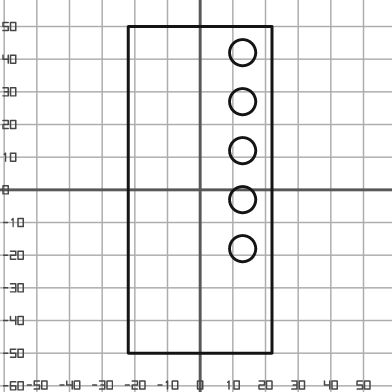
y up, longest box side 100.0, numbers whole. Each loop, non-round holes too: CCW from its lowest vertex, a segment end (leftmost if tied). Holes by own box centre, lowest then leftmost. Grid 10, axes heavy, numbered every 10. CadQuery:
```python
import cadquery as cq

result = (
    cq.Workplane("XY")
    .moveTo(-22.0, -50.0)
    .lineTo(22.0, -50.0)
    .lineTo(22.0, 50.0)
    .lineTo(-22.0, 50.0)
    .close()
    .moveTo(13.0, -18.0)
    .circle(4.0)
    .moveTo(13.0, -3.0)
    .circle(4.0)
    .moveTo(13.0, 12.0)
    .circle(4.0)
    .moveTo(13.0, 27.0)
    .circle(4.0)
    .moveTo(13.0, 42.0)
    .circle(4.0)
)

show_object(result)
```